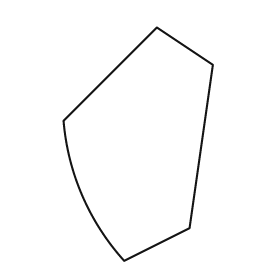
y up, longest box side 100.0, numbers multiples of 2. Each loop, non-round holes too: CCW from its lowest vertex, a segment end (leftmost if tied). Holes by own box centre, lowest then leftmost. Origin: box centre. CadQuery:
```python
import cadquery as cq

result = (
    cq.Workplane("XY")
    .moveTo(-6.0, -50.0)
    .lineTo(22.0, -36.0)
    .lineTo(32.0, 34.0)
    .lineTo(8.0, 50.0)
    .lineTo(-32.0, 10.0)
    .threePointArc((-24.0, -22.0), (-6.0, -50.0))
    .close()
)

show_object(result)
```